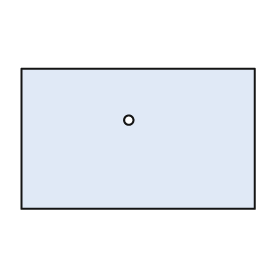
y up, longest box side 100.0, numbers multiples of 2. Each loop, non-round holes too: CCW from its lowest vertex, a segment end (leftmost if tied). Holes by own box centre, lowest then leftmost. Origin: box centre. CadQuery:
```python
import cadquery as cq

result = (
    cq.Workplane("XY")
    .moveTo(-50.0, -30.0)
    .lineTo(50.0, -30.0)
    .lineTo(50.0, 30.0)
    .lineTo(-50.0, 30.0)
    .close()
    .moveTo(-4.0, 8.0)
    .circle(2.0)
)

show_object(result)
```